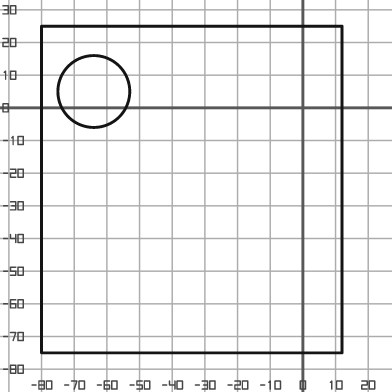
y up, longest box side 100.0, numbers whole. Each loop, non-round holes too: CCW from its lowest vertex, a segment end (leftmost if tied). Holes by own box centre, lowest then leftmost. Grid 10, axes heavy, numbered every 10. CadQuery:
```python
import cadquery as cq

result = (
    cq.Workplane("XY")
    .moveTo(-80.0, -75.0)
    .lineTo(12.0, -75.0)
    .lineTo(12.0, 25.0)
    .lineTo(-80.0, 25.0)
    .close()
    .moveTo(-64.0, 5.0)
    .circle(11.0)
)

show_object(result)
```